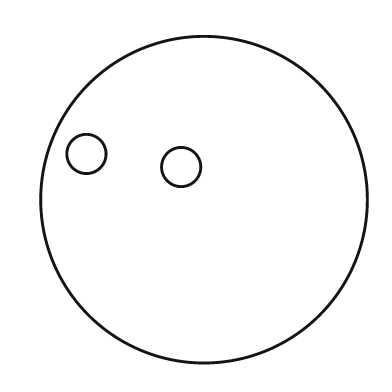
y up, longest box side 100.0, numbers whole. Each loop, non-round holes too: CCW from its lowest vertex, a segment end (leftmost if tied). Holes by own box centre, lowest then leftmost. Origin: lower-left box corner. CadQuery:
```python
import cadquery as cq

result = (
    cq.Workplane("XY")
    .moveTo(50.0, 50.0)
    .circle(50.0)
    .moveTo(43.0, 60.0)
    .circle(6.0)
    .moveTo(14.0, 64.0)
    .circle(6.0)
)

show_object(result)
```